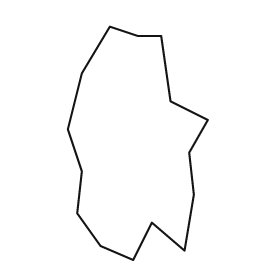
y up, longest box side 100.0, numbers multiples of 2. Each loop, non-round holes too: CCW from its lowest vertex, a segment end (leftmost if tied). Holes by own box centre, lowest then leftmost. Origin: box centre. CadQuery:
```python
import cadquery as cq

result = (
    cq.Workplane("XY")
    .moveTo(-2.0, -50.0)
    .lineTo(6.0, -34.0)
    .lineTo(20.0, -46.0)
    .lineTo(24.0, -22.0)
    .lineTo(22.0, -4.0)
    .lineTo(30.0, 10.0)
    .lineTo(14.0, 18.0)
    .lineTo(10.0, 46.0)
    .lineTo(0.0, 46.0)
    .lineTo(-12.0, 50.0)
    .lineTo(-24.0, 30.0)
    .lineTo(-30.0, 6.0)
    .lineTo(-24.0, -12.0)
    .lineTo(-26.0, -30.0)
    .lineTo(-16.0, -44.0)
    .close()
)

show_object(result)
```